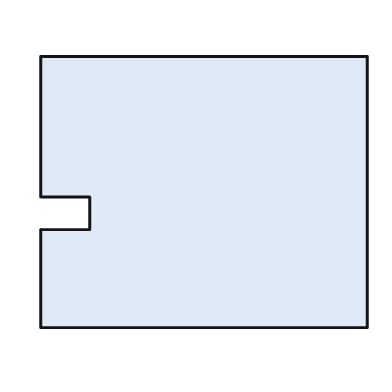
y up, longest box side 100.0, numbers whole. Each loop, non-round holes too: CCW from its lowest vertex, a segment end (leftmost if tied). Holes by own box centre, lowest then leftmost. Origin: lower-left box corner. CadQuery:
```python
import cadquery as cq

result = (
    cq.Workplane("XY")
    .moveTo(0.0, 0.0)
    .lineTo(100.0, 0.0)
    .lineTo(100.0, 83.0)
    .lineTo(0.0, 83.0)
    .lineTo(0.0, 40.0)
    .lineTo(15.0, 40.0)
    .lineTo(15.0, 30.0)
    .lineTo(0.0, 30.0)
    .close()
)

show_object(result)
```